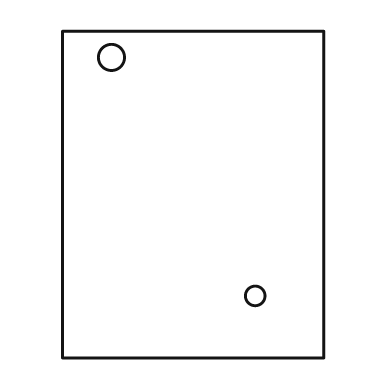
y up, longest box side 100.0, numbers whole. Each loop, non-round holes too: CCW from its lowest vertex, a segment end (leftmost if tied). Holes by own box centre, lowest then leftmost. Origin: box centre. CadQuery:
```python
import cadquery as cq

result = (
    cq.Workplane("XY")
    .moveTo(-40.0, -50.0)
    .lineTo(40.0, -50.0)
    .lineTo(40.0, 50.0)
    .lineTo(-40.0, 50.0)
    .close()
    .moveTo(19.0, -31.0)
    .circle(3.0)
    .moveTo(-25.0, 42.0)
    .circle(4.0)
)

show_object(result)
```